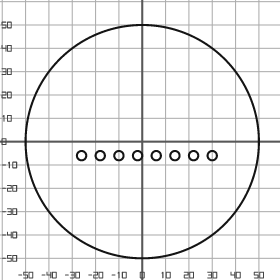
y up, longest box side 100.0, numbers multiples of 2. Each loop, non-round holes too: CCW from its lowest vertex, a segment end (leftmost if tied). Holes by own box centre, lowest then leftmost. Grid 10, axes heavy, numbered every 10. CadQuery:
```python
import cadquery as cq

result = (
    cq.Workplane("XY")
    .moveTo(0.0, 0.0)
    .circle(50.0)
    .moveTo(-26.0, -6.0)
    .circle(2.0)
    .moveTo(-18.0, -6.0)
    .circle(2.0)
    .moveTo(-10.0, -6.0)
    .circle(2.0)
    .moveTo(-2.0, -6.0)
    .circle(2.0)
    .moveTo(6.0, -6.0)
    .circle(2.0)
    .moveTo(14.0, -6.0)
    .circle(2.0)
    .moveTo(22.0, -6.0)
    .circle(2.0)
    .moveTo(30.0, -6.0)
    .circle(2.0)
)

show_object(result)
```